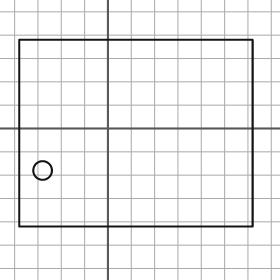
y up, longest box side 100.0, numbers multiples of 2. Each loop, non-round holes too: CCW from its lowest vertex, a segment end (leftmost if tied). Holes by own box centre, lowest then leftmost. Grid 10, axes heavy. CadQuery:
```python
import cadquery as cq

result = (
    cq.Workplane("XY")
    .moveTo(-38.0, -42.0)
    .lineTo(62.0, -42.0)
    .lineTo(62.0, 38.0)
    .lineTo(-38.0, 38.0)
    .close()
    .moveTo(-28.0, -18.0)
    .circle(4.0)
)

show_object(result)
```